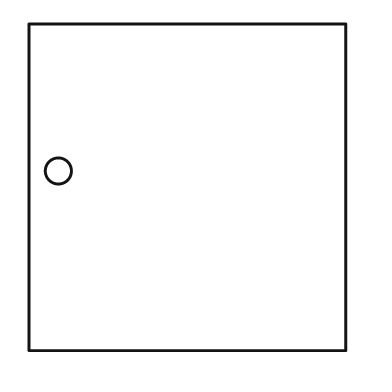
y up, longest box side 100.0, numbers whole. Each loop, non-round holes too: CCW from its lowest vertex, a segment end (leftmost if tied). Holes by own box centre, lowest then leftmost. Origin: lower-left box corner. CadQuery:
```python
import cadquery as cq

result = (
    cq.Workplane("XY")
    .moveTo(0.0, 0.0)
    .lineTo(97.0, 0.0)
    .lineTo(97.0, 100.0)
    .lineTo(0.0, 100.0)
    .close()
    .moveTo(9.0, 55.0)
    .circle(4.0)
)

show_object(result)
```